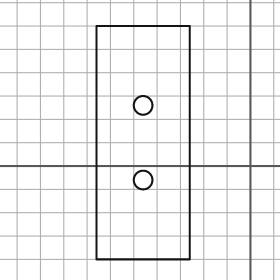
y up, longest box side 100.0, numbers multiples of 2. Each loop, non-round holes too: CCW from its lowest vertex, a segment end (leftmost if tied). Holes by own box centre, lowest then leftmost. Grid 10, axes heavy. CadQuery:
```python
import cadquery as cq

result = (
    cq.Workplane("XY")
    .moveTo(-66.0, -40.0)
    .lineTo(-26.0, -40.0)
    .lineTo(-26.0, 60.0)
    .lineTo(-66.0, 60.0)
    .close()
    .moveTo(-46.0, -6.0)
    .circle(4.0)
    .moveTo(-46.0, 26.0)
    .circle(4.0)
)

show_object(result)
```